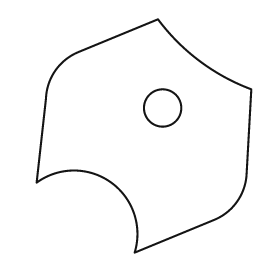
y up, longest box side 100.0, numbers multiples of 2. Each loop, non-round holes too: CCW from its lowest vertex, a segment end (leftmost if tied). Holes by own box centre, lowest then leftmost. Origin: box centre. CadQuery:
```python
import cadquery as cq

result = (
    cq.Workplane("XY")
    .moveTo(-4.0, -50.0)
    .lineTo(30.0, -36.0)
    .threePointArc((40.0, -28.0), (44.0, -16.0))
    .lineTo(46.0, 20.0)
    .threePointArc((24.0, 32.0), (6.0, 50.0))
    .lineTo(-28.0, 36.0)
    .threePointArc((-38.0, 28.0), (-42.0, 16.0))
    .lineTo(-46.0, -20.0)
    .threePointArc((-14.0, -20.0), (-4.0, -50.0))
    .close()
    .moveTo(8.0, 12.0)
    .circle(8.0)
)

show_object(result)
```